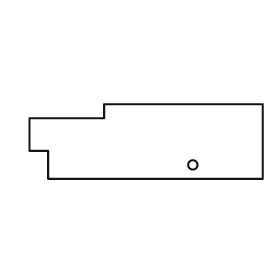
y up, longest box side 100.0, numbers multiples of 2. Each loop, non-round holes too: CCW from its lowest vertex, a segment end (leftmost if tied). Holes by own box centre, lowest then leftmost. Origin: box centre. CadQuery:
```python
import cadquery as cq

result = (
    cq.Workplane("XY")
    .moveTo(-42.0, -16.0)
    .lineTo(50.0, -16.0)
    .lineTo(50.0, 16.0)
    .lineTo(-18.0, 16.0)
    .lineTo(-18.0, 10.0)
    .lineTo(-50.0, 10.0)
    .lineTo(-50.0, -4.0)
    .lineTo(-42.0, -4.0)
    .close()
    .moveTo(20.0, -10.0)
    .circle(2.0)
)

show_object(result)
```